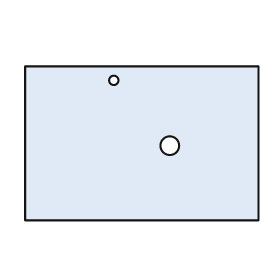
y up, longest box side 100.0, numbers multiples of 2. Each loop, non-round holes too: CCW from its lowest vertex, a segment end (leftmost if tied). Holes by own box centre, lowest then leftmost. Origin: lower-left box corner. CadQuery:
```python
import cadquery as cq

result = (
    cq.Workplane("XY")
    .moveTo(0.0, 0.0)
    .lineTo(100.0, 0.0)
    .lineTo(100.0, 66.0)
    .lineTo(0.0, 66.0)
    .close()
    .moveTo(62.0, 32.0)
    .circle(4.0)
    .moveTo(38.0, 60.0)
    .circle(2.0)
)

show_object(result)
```